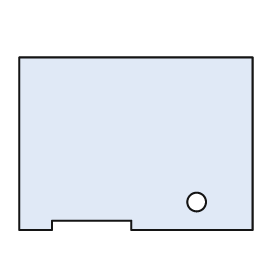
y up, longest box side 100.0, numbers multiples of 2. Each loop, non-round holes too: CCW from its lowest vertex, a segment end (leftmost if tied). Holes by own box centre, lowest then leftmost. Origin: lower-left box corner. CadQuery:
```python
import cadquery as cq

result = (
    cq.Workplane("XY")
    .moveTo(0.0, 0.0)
    .lineTo(14.0, 0.0)
    .lineTo(14.0, 4.0)
    .lineTo(48.0, 4.0)
    .lineTo(48.0, 0.0)
    .lineTo(100.0, 0.0)
    .lineTo(100.0, 74.0)
    .lineTo(0.0, 74.0)
    .close()
    .moveTo(76.0, 12.0)
    .circle(4.0)
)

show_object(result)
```